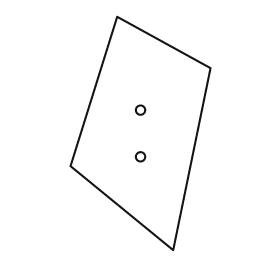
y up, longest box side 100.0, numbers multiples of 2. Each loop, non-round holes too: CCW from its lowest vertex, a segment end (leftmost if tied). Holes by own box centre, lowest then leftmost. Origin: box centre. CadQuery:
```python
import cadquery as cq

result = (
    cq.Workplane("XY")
    .moveTo(14.0, -50.0)
    .lineTo(30.0, 28.0)
    .lineTo(-10.0, 50.0)
    .lineTo(-30.0, -14.0)
    .close()
    .moveTo(0.0, -10.0)
    .circle(2.0)
    .moveTo(0.0, 10.0)
    .circle(2.0)
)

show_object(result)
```